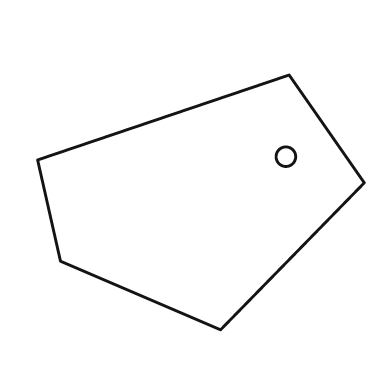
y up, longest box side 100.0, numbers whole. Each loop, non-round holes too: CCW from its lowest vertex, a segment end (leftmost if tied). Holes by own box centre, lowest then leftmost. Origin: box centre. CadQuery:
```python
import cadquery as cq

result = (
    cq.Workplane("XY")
    .moveTo(6.0, -39.0)
    .lineTo(50.0, 6.0)
    .lineTo(27.0, 39.0)
    .lineTo(-50.0, 13.0)
    .lineTo(-43.0, -18.0)
    .close()
    .moveTo(26.0, 14.0)
    .circle(3.0)
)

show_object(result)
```